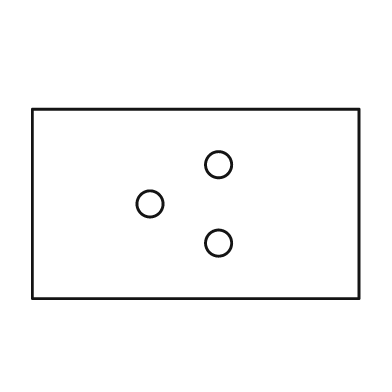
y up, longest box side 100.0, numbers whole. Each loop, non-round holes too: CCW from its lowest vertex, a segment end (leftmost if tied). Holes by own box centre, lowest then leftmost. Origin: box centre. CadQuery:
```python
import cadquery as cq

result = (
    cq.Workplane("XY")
    .moveTo(-50.0, -29.0)
    .lineTo(50.0, -29.0)
    .lineTo(50.0, 29.0)
    .lineTo(-50.0, 29.0)
    .close()
    .moveTo(7.0, -12.0)
    .circle(4.0)
    .moveTo(-14.0, 0.0)
    .circle(4.0)
    .moveTo(7.0, 12.0)
    .circle(4.0)
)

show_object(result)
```